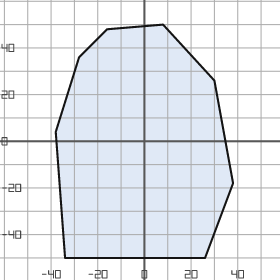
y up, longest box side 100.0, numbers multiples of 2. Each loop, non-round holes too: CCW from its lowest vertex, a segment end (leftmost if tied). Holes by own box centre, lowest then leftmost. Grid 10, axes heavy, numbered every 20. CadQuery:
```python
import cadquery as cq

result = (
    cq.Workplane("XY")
    .moveTo(-34.0, -50.0)
    .lineTo(26.0, -50.0)
    .lineTo(38.0, -18.0)
    .lineTo(30.0, 26.0)
    .lineTo(8.0, 50.0)
    .lineTo(-16.0, 48.0)
    .lineTo(-28.0, 36.0)
    .lineTo(-38.0, 4.0)
    .close()
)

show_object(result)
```